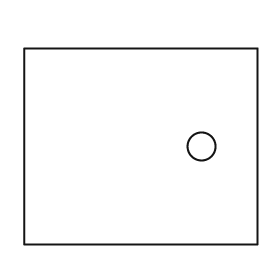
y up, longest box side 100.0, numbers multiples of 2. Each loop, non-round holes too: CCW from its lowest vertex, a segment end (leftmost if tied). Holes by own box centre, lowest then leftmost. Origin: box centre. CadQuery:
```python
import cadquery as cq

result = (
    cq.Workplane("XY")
    .moveTo(-50.0, -42.0)
    .lineTo(50.0, -42.0)
    .lineTo(50.0, 42.0)
    .lineTo(-50.0, 42.0)
    .close()
    .moveTo(26.0, 0.0)
    .circle(6.0)
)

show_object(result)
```